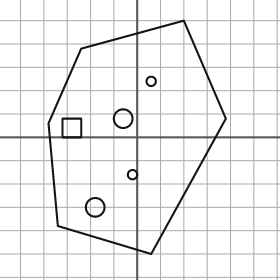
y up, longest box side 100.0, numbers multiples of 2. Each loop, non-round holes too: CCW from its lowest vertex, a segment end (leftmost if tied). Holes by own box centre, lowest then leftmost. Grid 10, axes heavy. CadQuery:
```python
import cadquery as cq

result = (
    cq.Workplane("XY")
    .moveTo(6.0, -50.0)
    .lineTo(38.0, 8.0)
    .lineTo(20.0, 50.0)
    .lineTo(-24.0, 38.0)
    .lineTo(-38.0, 6.0)
    .lineTo(-34.0, -38.0)
    .close()
    .moveTo(-18.0, -30.0)
    .circle(4.0)
    .moveTo(-2.0, -16.0)
    .circle(2.0)
    .moveTo(-32.0, 0.0)
    .lineTo(-24.0, 0.0)
    .lineTo(-24.0, 8.0)
    .lineTo(-32.0, 8.0)
    .close()
    .moveTo(-6.0, 8.0)
    .circle(4.0)
    .moveTo(6.0, 24.0)
    .circle(2.0)
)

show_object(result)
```